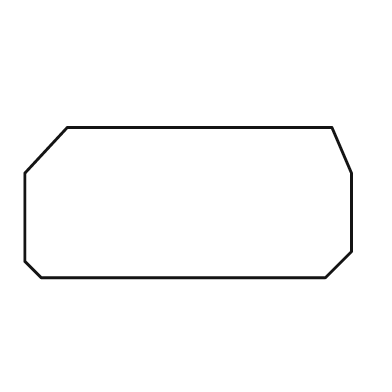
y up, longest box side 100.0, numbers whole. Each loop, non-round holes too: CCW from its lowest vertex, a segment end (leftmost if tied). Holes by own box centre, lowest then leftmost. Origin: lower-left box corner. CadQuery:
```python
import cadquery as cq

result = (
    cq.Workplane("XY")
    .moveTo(5.0, 0.0)
    .lineTo(92.0, 0.0)
    .lineTo(100.0, 8.0)
    .lineTo(100.0, 32.0)
    .lineTo(94.0, 46.0)
    .lineTo(13.0, 46.0)
    .lineTo(0.0, 32.0)
    .lineTo(0.0, 5.0)
    .close()
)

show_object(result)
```